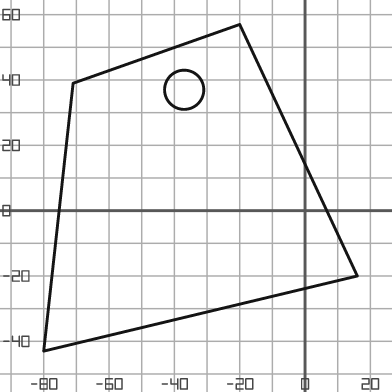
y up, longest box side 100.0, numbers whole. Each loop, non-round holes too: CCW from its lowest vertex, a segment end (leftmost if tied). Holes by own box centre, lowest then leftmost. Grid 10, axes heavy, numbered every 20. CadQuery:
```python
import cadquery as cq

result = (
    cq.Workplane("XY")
    .moveTo(-80.0, -43.0)
    .lineTo(16.0, -20.0)
    .lineTo(-20.0, 57.0)
    .lineTo(-71.0, 39.0)
    .close()
    .moveTo(-37.0, 37.0)
    .circle(6.0)
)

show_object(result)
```